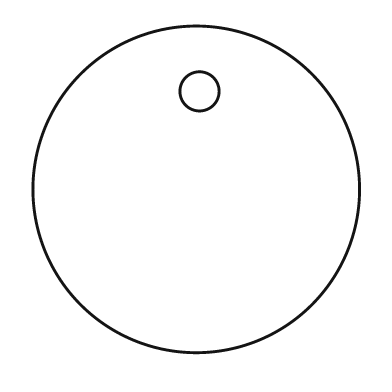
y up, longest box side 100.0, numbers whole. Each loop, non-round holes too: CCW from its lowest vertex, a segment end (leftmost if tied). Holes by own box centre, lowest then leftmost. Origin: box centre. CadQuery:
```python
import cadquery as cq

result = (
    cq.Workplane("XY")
    .moveTo(0.0, 0.0)
    .circle(50.0)
    .moveTo(1.0, 30.0)
    .circle(6.0)
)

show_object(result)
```